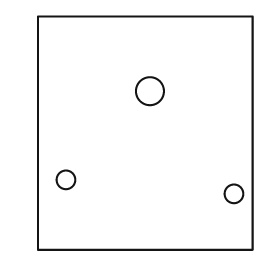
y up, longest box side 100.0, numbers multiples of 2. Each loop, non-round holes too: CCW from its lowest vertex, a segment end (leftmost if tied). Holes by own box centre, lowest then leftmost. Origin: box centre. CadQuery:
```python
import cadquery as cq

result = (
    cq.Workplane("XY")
    .moveTo(-46.0, -50.0)
    .lineTo(46.0, -50.0)
    .lineTo(46.0, 50.0)
    .lineTo(-46.0, 50.0)
    .close()
    .moveTo(38.0, -26.0)
    .circle(4.0)
    .moveTo(-34.0, -20.0)
    .circle(4.0)
    .moveTo(2.0, 18.0)
    .circle(6.0)
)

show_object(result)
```